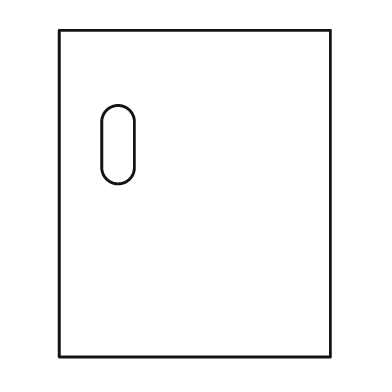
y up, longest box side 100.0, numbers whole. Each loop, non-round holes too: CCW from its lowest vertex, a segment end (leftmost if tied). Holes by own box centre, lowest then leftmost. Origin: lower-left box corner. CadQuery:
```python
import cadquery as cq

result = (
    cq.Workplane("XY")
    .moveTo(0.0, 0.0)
    .lineTo(83.0, 0.0)
    .lineTo(83.0, 100.0)
    .lineTo(0.0, 100.0)
    .close()
    .moveTo(13.0, 58.0)
    .threePointArc((18.0, 53.0), (23.0, 58.0))
    .lineTo(23.0, 72.0)
    .threePointArc((18.0, 77.0), (13.0, 72.0))
    .close()
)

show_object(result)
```